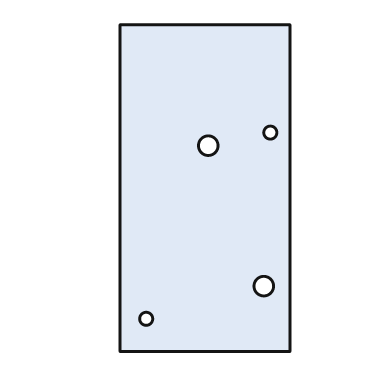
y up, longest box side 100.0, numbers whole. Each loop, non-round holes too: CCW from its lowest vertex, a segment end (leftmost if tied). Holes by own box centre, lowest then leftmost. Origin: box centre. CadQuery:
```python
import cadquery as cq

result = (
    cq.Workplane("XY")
    .moveTo(-26.0, -50.0)
    .lineTo(26.0, -50.0)
    .lineTo(26.0, 50.0)
    .lineTo(-26.0, 50.0)
    .close()
    .moveTo(-18.0, -40.0)
    .circle(2.0)
    .moveTo(18.0, -30.0)
    .circle(3.0)
    .moveTo(1.0, 13.0)
    .circle(3.0)
    .moveTo(20.0, 17.0)
    .circle(2.0)
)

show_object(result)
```